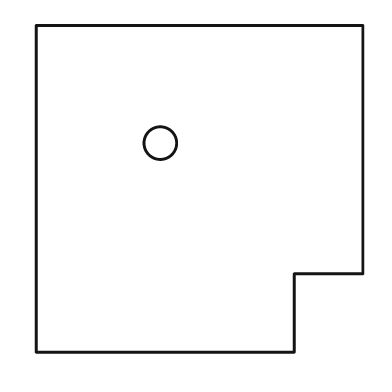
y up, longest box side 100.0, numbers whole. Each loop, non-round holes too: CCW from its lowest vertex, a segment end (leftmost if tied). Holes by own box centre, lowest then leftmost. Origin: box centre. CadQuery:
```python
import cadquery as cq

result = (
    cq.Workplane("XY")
    .moveTo(-50.0, -50.0)
    .lineTo(29.0, -50.0)
    .lineTo(29.0, -26.0)
    .lineTo(50.0, -26.0)
    .lineTo(50.0, 50.0)
    .lineTo(-50.0, 50.0)
    .close()
    .moveTo(-12.0, 14.0)
    .circle(5.0)
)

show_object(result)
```